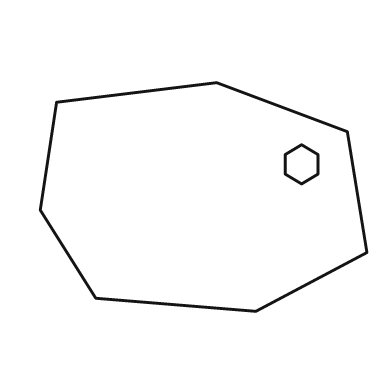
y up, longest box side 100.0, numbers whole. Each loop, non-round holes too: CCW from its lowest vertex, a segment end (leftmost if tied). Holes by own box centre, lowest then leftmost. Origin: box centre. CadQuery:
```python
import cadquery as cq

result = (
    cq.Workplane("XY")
    .moveTo(16.0, -35.0)
    .lineTo(50.0, -17.0)
    .lineTo(44.0, 20.0)
    .lineTo(4.0, 35.0)
    .lineTo(-45.0, 29.0)
    .lineTo(-50.0, -4.0)
    .lineTo(-33.0, -31.0)
    .close()
    .moveTo(30.0, 4.0)
    .lineTo(35.0, 7.0)
    .lineTo(35.0, 13.0)
    .lineTo(30.0, 16.0)
    .lineTo(25.0, 13.0)
    .lineTo(25.0, 7.0)
    .close()
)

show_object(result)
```